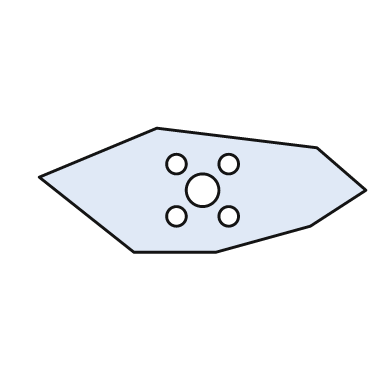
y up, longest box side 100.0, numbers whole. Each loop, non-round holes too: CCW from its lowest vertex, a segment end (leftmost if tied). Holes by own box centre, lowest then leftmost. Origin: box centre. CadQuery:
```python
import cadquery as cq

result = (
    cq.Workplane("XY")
    .moveTo(-21.0, -19.0)
    .lineTo(4.0, -19.0)
    .lineTo(33.0, -11.0)
    .lineTo(50.0, 0.0)
    .lineTo(35.0, 13.0)
    .lineTo(-14.0, 19.0)
    .lineTo(-50.0, 4.0)
    .close()
    .moveTo(-8.0, -8.0)
    .circle(3.0)
    .moveTo(8.0, -8.0)
    .circle(3.0)
    .moveTo(0.0, 0.0)
    .circle(5.0)
    .moveTo(-8.0, 8.0)
    .circle(3.0)
    .moveTo(8.0, 8.0)
    .circle(3.0)
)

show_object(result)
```